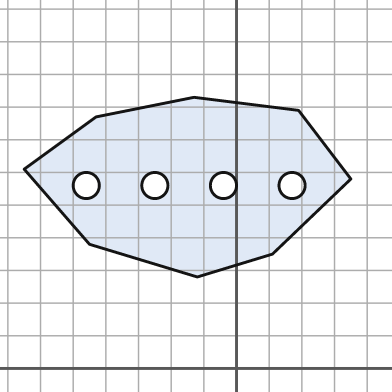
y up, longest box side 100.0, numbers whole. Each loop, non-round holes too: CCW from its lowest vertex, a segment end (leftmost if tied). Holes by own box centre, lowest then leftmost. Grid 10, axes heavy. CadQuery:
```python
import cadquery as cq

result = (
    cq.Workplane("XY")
    .moveTo(-12.0, 28.0)
    .lineTo(11.0, 35.0)
    .lineTo(35.0, 58.0)
    .lineTo(19.0, 79.0)
    .lineTo(-13.0, 83.0)
    .lineTo(-43.0, 77.0)
    .lineTo(-65.0, 61.0)
    .lineTo(-45.0, 38.0)
    .close()
    .moveTo(-46.0, 56.0)
    .circle(4.0)
    .moveTo(-25.0, 56.0)
    .circle(4.0)
    .moveTo(-4.0, 56.0)
    .circle(4.0)
    .moveTo(17.0, 56.0)
    .circle(4.0)
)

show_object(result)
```